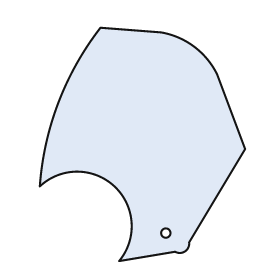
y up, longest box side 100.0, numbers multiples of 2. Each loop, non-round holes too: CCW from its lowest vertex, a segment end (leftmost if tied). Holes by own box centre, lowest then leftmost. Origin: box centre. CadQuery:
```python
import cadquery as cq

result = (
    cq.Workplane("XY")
    .moveTo(-10.0, -50.0)
    .lineTo(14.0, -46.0)
    .threePointArc((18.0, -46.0), (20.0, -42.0))
    .lineTo(44.0, -2.0)
    .lineTo(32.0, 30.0)
    .threePointArc((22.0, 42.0), (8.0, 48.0))
    .lineTo(-18.0, 50.0)
    .threePointArc((-36.0, 18.0), (-44.0, -18.0))
    .threePointArc((-12.0, -18.0), (-10.0, -50.0))
    .close()
    .moveTo(10.0, -38.0)
    .circle(2.0)
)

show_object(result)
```